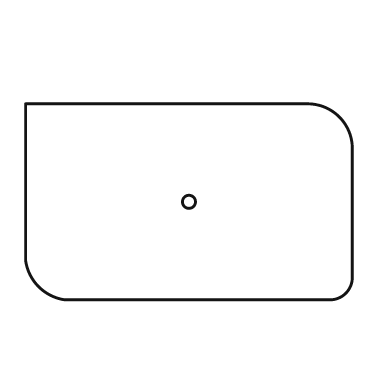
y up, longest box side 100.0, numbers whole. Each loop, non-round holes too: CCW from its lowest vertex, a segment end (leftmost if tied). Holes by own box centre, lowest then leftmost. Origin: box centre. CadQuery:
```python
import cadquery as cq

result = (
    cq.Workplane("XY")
    .moveTo(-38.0, -30.0)
    .lineTo(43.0, -30.0)
    .threePointArc((48.0, -28.0), (50.0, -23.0))
    .lineTo(50.0, 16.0)
    .threePointArc((46.0, 26.0), (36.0, 30.0))
    .lineTo(-50.0, 30.0)
    .lineTo(-50.0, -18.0)
    .threePointArc((-46.0, -26.0), (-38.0, -30.0))
    .close()
    .moveTo(0.0, 0.0)
    .circle(2.0)
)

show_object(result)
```